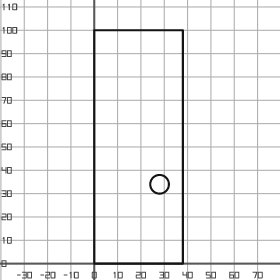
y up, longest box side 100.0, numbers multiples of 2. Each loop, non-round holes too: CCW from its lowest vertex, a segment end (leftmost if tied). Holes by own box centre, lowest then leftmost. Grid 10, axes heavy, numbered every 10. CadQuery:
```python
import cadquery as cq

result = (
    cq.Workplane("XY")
    .moveTo(0.0, 0.0)
    .lineTo(38.0, 0.0)
    .lineTo(38.0, 100.0)
    .lineTo(0.0, 100.0)
    .close()
    .moveTo(28.0, 34.0)
    .circle(4.0)
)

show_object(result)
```